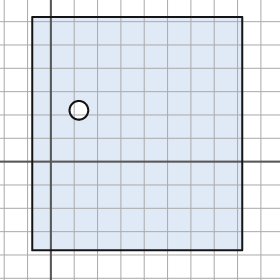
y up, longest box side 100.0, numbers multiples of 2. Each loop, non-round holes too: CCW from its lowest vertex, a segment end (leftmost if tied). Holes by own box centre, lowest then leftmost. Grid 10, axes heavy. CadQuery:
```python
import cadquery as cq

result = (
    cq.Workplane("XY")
    .moveTo(-8.0, -38.0)
    .lineTo(82.0, -38.0)
    .lineTo(82.0, 62.0)
    .lineTo(-8.0, 62.0)
    .close()
    .moveTo(12.0, 22.0)
    .circle(4.0)
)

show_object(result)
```